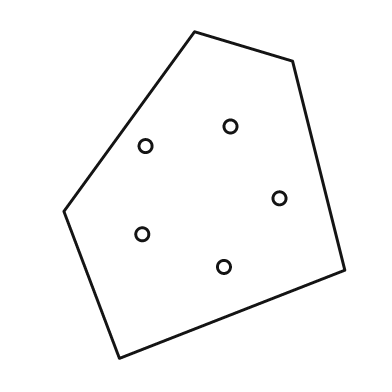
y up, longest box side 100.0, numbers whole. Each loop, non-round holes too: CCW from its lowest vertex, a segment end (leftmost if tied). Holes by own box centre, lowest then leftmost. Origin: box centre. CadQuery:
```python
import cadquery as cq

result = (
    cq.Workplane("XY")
    .moveTo(-26.0, -50.0)
    .lineTo(43.0, -23.0)
    .lineTo(27.0, 41.0)
    .lineTo(-3.0, 50.0)
    .lineTo(-43.0, -5.0)
    .close()
    .moveTo(6.0, -22.0)
    .circle(2.0)
    .moveTo(-19.0, -12.0)
    .circle(2.0)
    .moveTo(23.0, -1.0)
    .circle(2.0)
    .moveTo(-18.0, 15.0)
    .circle(2.0)
    .moveTo(8.0, 21.0)
    .circle(2.0)
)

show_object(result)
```